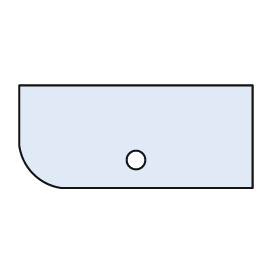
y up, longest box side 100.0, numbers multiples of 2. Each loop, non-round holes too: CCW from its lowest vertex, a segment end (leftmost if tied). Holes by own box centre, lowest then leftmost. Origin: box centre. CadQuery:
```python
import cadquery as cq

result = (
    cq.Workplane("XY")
    .moveTo(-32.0, -22.0)
    .lineTo(50.0, -22.0)
    .lineTo(50.0, 22.0)
    .lineTo(-50.0, 22.0)
    .lineTo(-50.0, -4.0)
    .threePointArc((-44.0, -16.0), (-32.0, -22.0))
    .close()
    .moveTo(0.0, -10.0)
    .circle(4.0)
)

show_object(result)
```